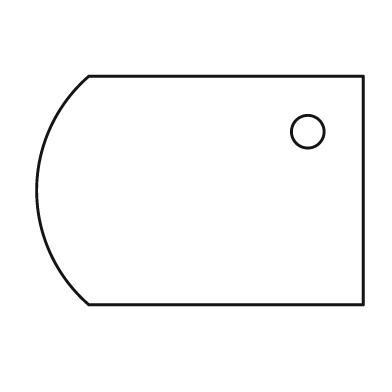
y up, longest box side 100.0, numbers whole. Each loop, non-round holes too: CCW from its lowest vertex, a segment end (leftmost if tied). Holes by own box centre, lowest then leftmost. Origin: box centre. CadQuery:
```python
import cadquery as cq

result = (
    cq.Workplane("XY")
    .moveTo(-34.0, -35.0)
    .lineTo(50.0, -35.0)
    .lineTo(50.0, 35.0)
    .lineTo(-34.0, 35.0)
    .threePointArc((-50.0, 0.0), (-34.0, -35.0))
    .close()
    .moveTo(33.0, 18.0)
    .circle(5.0)
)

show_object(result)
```